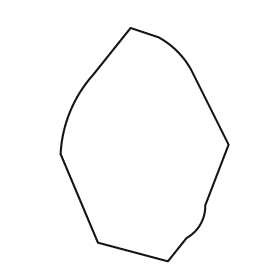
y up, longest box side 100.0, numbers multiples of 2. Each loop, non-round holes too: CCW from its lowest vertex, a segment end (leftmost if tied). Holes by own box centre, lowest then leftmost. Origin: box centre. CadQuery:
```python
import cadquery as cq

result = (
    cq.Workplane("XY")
    .moveTo(10.0, -50.0)
    .lineTo(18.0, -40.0)
    .threePointArc((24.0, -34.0), (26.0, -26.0))
    .lineTo(36.0, 0.0)
    .lineTo(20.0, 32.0)
    .threePointArc((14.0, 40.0), (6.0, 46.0))
    .lineTo(-6.0, 50.0)
    .lineTo(-22.0, 30.0)
    .threePointArc((-32.0, 14.0), (-36.0, -4.0))
    .lineTo(-20.0, -42.0)
    .close()
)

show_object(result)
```